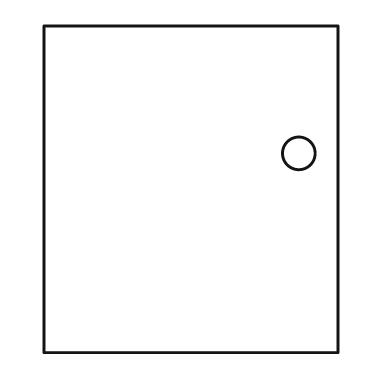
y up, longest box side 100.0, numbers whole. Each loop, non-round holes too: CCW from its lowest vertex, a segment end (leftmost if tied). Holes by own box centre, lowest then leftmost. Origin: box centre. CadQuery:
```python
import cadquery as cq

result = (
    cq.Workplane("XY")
    .moveTo(-45.0, -50.0)
    .lineTo(45.0, -50.0)
    .lineTo(45.0, 50.0)
    .lineTo(-45.0, 50.0)
    .close()
    .moveTo(33.0, 11.0)
    .circle(5.0)
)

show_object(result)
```